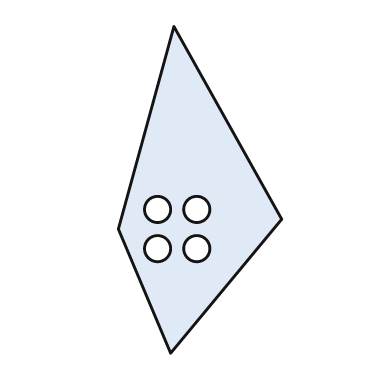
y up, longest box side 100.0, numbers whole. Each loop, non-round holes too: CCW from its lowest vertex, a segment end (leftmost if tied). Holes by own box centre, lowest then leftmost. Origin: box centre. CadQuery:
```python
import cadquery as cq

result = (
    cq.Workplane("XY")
    .moveTo(-9.0, -50.0)
    .lineTo(25.0, -9.0)
    .lineTo(-8.0, 50.0)
    .lineTo(-25.0, -12.0)
    .close()
    .moveTo(-13.0, -18.0)
    .circle(4.0)
    .moveTo(-1.0, -18.0)
    .circle(4.0)
    .moveTo(-13.0, -6.0)
    .circle(4.0)
    .moveTo(-1.0, -6.0)
    .circle(4.0)
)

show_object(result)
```